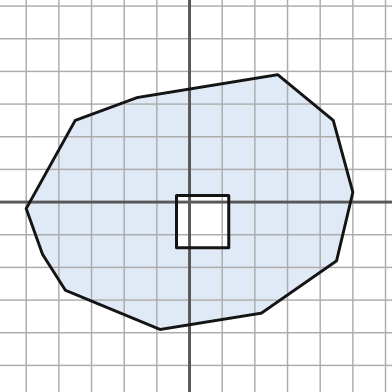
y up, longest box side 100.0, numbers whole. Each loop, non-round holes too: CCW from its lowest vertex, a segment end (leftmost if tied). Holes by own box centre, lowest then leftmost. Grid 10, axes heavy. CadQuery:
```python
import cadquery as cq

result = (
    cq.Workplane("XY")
    .moveTo(-9.0, -39.0)
    .lineTo(22.0, -34.0)
    .lineTo(45.0, -18.0)
    .lineTo(50.0, 3.0)
    .lineTo(44.0, 25.0)
    .lineTo(27.0, 39.0)
    .lineTo(-16.0, 32.0)
    .lineTo(-35.0, 25.0)
    .lineTo(-50.0, -2.0)
    .lineTo(-45.0, -16.0)
    .lineTo(-38.0, -27.0)
    .close()
    .moveTo(-4.0, -14.0)
    .lineTo(12.0, -14.0)
    .lineTo(12.0, 2.0)
    .lineTo(-4.0, 2.0)
    .close()
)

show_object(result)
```